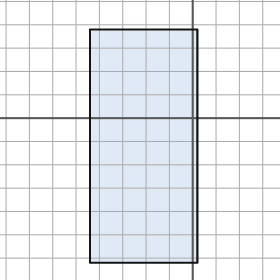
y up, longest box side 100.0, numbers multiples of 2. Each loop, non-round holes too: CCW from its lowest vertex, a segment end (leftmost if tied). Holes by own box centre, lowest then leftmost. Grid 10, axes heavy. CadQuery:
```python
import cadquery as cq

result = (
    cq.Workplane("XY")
    .moveTo(-44.0, -62.0)
    .lineTo(2.0, -62.0)
    .lineTo(2.0, 38.0)
    .lineTo(-44.0, 38.0)
    .close()
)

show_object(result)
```